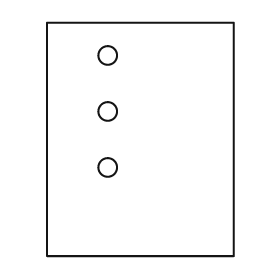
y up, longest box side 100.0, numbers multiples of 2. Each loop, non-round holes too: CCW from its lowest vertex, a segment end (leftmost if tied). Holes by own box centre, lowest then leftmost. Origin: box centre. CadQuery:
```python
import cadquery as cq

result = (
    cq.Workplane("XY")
    .moveTo(-40.0, -50.0)
    .lineTo(40.0, -50.0)
    .lineTo(40.0, 50.0)
    .lineTo(-40.0, 50.0)
    .close()
    .moveTo(-14.0, -12.0)
    .circle(4.0)
    .moveTo(-14.0, 12.0)
    .circle(4.0)
    .moveTo(-14.0, 36.0)
    .circle(4.0)
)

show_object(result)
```